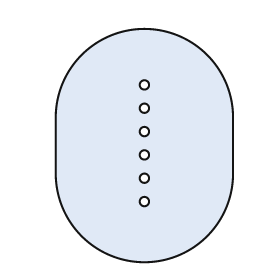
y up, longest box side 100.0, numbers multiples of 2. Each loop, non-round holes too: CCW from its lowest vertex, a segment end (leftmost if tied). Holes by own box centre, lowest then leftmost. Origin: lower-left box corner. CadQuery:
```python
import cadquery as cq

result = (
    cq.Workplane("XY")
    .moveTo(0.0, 38.0)
    .threePointArc((38.0, 0.0), (76.0, 38.0))
    .lineTo(76.0, 62.0)
    .threePointArc((38.0, 100.0), (0.0, 62.0))
    .close()
    .moveTo(38.0, 26.0)
    .circle(2.0)
    .moveTo(38.0, 36.0)
    .circle(2.0)
    .moveTo(38.0, 46.0)
    .circle(2.0)
    .moveTo(38.0, 56.0)
    .circle(2.0)
    .moveTo(38.0, 66.0)
    .circle(2.0)
    .moveTo(38.0, 76.0)
    .circle(2.0)
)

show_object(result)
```